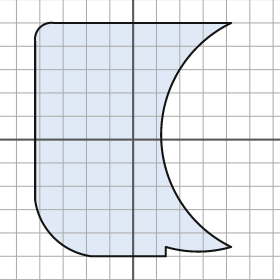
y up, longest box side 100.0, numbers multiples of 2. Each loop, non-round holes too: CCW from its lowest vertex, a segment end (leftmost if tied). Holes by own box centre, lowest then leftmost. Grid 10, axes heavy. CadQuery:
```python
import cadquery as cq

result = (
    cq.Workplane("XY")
    .moveTo(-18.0, -50.0)
    .lineTo(14.0, -50.0)
    .lineTo(14.0, -46.0)
    .threePointArc((28.0, -48.0), (42.0, -46.0))
    .threePointArc((12.0, 2.0), (42.0, 50.0))
    .lineTo(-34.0, 50.0)
    .threePointArc((-40.0, 48.0), (-42.0, 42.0))
    .lineTo(-42.0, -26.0)
    .threePointArc((-34.0, -42.0), (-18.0, -50.0))
    .close()
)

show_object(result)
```